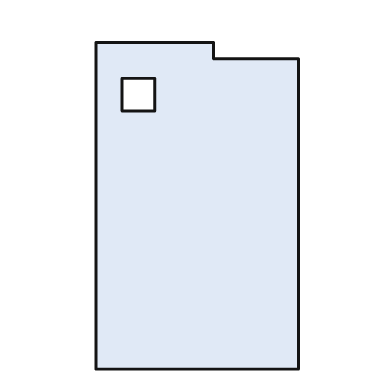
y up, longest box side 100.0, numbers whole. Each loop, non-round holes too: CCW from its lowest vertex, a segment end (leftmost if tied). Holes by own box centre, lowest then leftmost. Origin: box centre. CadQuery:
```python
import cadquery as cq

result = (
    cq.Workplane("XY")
    .moveTo(-31.0, -50.0)
    .lineTo(31.0, -50.0)
    .lineTo(31.0, 45.0)
    .lineTo(5.0, 45.0)
    .lineTo(5.0, 50.0)
    .lineTo(-31.0, 50.0)
    .close()
    .moveTo(-23.0, 29.0)
    .lineTo(-13.0, 29.0)
    .lineTo(-13.0, 39.0)
    .lineTo(-23.0, 39.0)
    .close()
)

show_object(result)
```